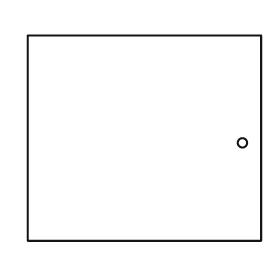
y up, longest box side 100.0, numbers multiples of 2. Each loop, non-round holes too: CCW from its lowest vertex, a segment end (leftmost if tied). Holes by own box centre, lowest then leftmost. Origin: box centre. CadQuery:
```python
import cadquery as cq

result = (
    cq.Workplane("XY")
    .moveTo(-50.0, -44.0)
    .lineTo(50.0, -44.0)
    .lineTo(50.0, 44.0)
    .lineTo(-50.0, 44.0)
    .close()
    .moveTo(42.0, -2.0)
    .circle(2.0)
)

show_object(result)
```